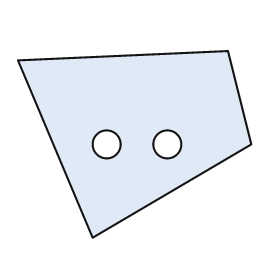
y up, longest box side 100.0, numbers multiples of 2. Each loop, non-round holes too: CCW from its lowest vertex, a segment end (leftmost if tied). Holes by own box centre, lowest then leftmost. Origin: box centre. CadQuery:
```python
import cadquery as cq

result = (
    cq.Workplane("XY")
    .moveTo(-18.0, -40.0)
    .lineTo(50.0, 0.0)
    .lineTo(40.0, 40.0)
    .lineTo(-50.0, 36.0)
    .close()
    .moveTo(-12.0, 0.0)
    .circle(6.0)
    .moveTo(14.0, 0.0)
    .circle(6.0)
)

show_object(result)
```